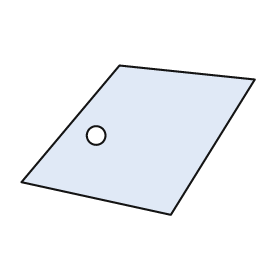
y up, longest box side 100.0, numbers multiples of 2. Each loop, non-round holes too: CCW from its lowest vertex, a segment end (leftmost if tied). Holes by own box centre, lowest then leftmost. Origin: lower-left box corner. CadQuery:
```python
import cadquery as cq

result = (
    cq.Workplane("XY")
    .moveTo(64.0, 0.0)
    .lineTo(100.0, 58.0)
    .lineTo(42.0, 64.0)
    .lineTo(0.0, 14.0)
    .close()
    .moveTo(32.0, 34.0)
    .circle(4.0)
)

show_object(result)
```